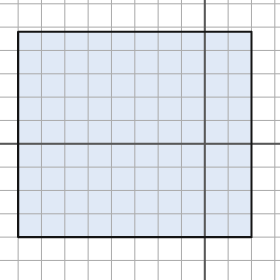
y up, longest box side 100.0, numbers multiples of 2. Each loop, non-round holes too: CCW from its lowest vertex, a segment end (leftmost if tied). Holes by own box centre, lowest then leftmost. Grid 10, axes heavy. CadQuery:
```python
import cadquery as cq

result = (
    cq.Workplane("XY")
    .moveTo(-80.0, -40.0)
    .lineTo(20.0, -40.0)
    .lineTo(20.0, 48.0)
    .lineTo(-80.0, 48.0)
    .close()
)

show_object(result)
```